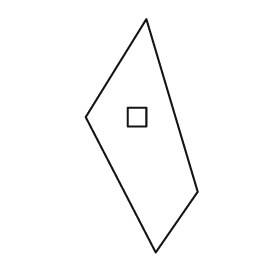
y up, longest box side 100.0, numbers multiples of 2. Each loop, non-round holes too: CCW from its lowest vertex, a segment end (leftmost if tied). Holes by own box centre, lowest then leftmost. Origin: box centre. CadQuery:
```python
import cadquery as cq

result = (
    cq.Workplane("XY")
    .moveTo(6.0, -50.0)
    .lineTo(24.0, -24.0)
    .lineTo(2.0, 50.0)
    .lineTo(-24.0, 8.0)
    .close()
    .moveTo(-6.0, 4.0)
    .lineTo(2.0, 4.0)
    .lineTo(2.0, 12.0)
    .lineTo(-6.0, 12.0)
    .close()
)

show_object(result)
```